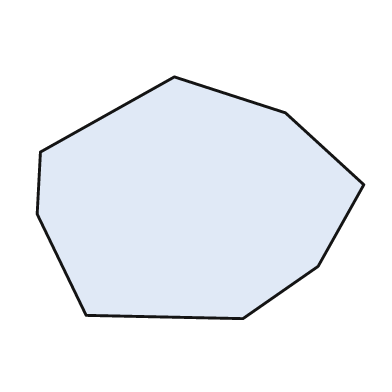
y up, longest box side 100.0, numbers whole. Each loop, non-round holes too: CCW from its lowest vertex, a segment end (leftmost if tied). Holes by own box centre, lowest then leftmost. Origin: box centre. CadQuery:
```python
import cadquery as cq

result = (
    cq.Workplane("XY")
    .moveTo(13.0, -37.0)
    .lineTo(36.0, -21.0)
    .lineTo(50.0, 4.0)
    .lineTo(26.0, 26.0)
    .lineTo(-8.0, 37.0)
    .lineTo(-49.0, 14.0)
    .lineTo(-50.0, -5.0)
    .lineTo(-35.0, -36.0)
    .close()
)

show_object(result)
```